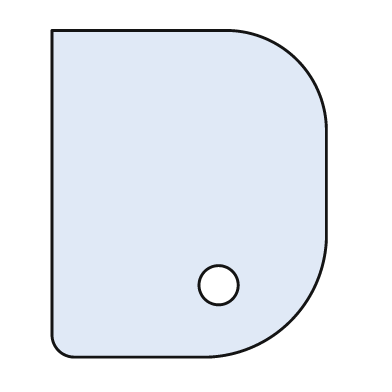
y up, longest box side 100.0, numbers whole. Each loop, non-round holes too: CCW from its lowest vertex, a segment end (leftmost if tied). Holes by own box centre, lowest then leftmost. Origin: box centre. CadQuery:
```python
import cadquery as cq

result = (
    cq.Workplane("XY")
    .moveTo(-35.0, -50.0)
    .lineTo(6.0, -50.0)
    .threePointArc((31.0, -39.0), (42.0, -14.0))
    .lineTo(42.0, 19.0)
    .threePointArc((33.0, 41.0), (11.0, 50.0))
    .lineTo(-42.0, 50.0)
    .lineTo(-42.0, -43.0)
    .threePointArc((-40.0, -48.0), (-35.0, -50.0))
    .close()
    .moveTo(9.0, -28.0)
    .circle(6.0)
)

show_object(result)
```